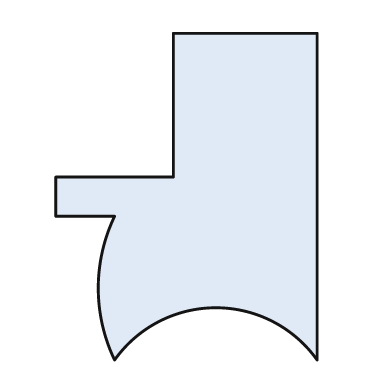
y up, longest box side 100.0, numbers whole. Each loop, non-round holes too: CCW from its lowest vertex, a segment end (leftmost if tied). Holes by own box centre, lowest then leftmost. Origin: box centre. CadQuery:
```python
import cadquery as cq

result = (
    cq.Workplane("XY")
    .moveTo(-22.0, -50.0)
    .threePointArc((9.0, -34.0), (40.0, -50.0))
    .lineTo(40.0, 50.0)
    .lineTo(-4.0, 50.0)
    .lineTo(-4.0, 6.0)
    .lineTo(-40.0, 6.0)
    .lineTo(-40.0, -6.0)
    .lineTo(-22.0, -6.0)
    .threePointArc((-27.0, -28.0), (-22.0, -50.0))
    .close()
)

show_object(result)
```